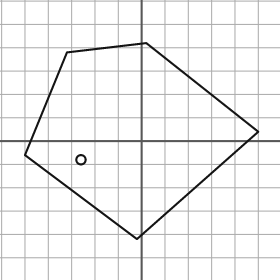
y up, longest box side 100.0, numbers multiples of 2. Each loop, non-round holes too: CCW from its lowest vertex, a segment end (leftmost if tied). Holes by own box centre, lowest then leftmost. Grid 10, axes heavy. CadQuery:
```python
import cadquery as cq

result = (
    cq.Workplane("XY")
    .moveTo(-2.0, -42.0)
    .lineTo(50.0, 4.0)
    .lineTo(2.0, 42.0)
    .lineTo(-32.0, 38.0)
    .lineTo(-50.0, -6.0)
    .close()
    .moveTo(-26.0, -8.0)
    .circle(2.0)
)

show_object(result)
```